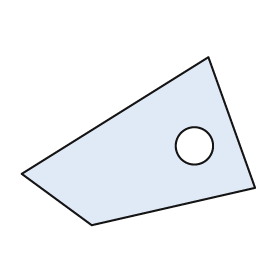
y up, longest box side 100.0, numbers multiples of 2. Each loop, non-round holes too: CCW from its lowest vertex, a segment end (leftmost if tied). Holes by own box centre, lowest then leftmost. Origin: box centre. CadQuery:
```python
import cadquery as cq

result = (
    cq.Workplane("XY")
    .moveTo(-20.0, -36.0)
    .lineTo(50.0, -20.0)
    .lineTo(30.0, 36.0)
    .lineTo(-50.0, -14.0)
    .close()
    .moveTo(24.0, -2.0)
    .circle(8.0)
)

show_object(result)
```